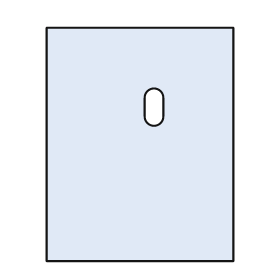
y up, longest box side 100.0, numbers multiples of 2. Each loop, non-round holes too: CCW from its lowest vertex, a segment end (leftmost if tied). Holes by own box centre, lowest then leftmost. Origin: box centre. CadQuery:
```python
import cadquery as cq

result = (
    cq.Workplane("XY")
    .moveTo(-40.0, -50.0)
    .lineTo(40.0, -50.0)
    .lineTo(40.0, 50.0)
    .lineTo(-40.0, 50.0)
    .close()
    .moveTo(2.0, 12.0)
    .threePointArc((6.0, 8.0), (10.0, 12.0))
    .lineTo(10.0, 20.0)
    .threePointArc((6.0, 24.0), (2.0, 20.0))
    .close()
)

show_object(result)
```